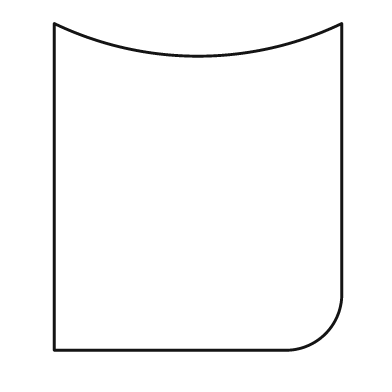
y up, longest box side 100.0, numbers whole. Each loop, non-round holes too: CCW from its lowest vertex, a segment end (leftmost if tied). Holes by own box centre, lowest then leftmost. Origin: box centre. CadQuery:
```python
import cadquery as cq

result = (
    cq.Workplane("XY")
    .moveTo(-44.0, -50.0)
    .lineTo(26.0, -50.0)
    .threePointArc((39.0, -45.0), (44.0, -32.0))
    .lineTo(44.0, 50.0)
    .threePointArc((0.0, 40.0), (-44.0, 50.0))
    .close()
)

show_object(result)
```